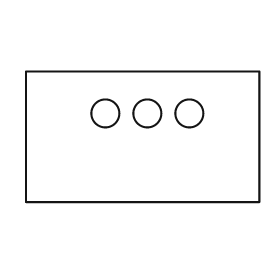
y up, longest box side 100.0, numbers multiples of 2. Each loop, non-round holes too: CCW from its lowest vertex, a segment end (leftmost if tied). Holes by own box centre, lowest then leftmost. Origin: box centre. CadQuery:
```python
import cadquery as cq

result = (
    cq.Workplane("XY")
    .moveTo(-50.0, -28.0)
    .lineTo(50.0, -28.0)
    .lineTo(50.0, 28.0)
    .lineTo(-50.0, 28.0)
    .close()
    .moveTo(-16.0, 10.0)
    .circle(6.0)
    .moveTo(2.0, 10.0)
    .circle(6.0)
    .moveTo(20.0, 10.0)
    .circle(6.0)
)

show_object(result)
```